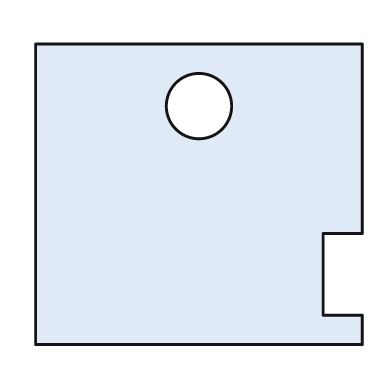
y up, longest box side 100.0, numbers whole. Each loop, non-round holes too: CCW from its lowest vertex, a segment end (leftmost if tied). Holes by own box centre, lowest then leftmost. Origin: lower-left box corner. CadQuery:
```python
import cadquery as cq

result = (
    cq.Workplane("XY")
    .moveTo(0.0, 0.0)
    .lineTo(100.0, 0.0)
    .lineTo(100.0, 9.0)
    .lineTo(88.0, 9.0)
    .lineTo(88.0, 34.0)
    .lineTo(100.0, 34.0)
    .lineTo(100.0, 92.0)
    .lineTo(0.0, 92.0)
    .close()
    .moveTo(50.0, 73.0)
    .circle(10.0)
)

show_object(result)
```